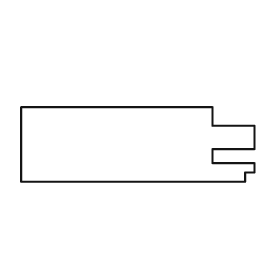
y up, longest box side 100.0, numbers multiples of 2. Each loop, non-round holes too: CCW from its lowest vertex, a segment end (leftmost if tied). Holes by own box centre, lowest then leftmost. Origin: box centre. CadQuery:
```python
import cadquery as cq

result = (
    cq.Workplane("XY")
    .moveTo(-50.0, -16.0)
    .lineTo(46.0, -16.0)
    .lineTo(46.0, -12.0)
    .lineTo(50.0, -12.0)
    .lineTo(50.0, -8.0)
    .lineTo(32.0, -8.0)
    .lineTo(32.0, -2.0)
    .lineTo(50.0, -2.0)
    .lineTo(50.0, 8.0)
    .lineTo(32.0, 8.0)
    .lineTo(32.0, 16.0)
    .lineTo(-50.0, 16.0)
    .close()
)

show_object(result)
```